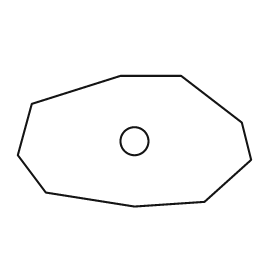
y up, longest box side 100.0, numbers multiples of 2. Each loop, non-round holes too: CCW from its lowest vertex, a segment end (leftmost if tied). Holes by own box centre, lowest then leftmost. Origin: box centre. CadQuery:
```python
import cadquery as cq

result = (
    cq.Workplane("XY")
    .moveTo(0.0, -28.0)
    .lineTo(30.0, -26.0)
    .lineTo(50.0, -8.0)
    .lineTo(46.0, 8.0)
    .lineTo(20.0, 28.0)
    .lineTo(-6.0, 28.0)
    .lineTo(-44.0, 16.0)
    .lineTo(-50.0, -6.0)
    .lineTo(-38.0, -22.0)
    .close()
    .moveTo(0.0, 0.0)
    .circle(6.0)
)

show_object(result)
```